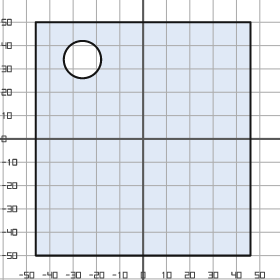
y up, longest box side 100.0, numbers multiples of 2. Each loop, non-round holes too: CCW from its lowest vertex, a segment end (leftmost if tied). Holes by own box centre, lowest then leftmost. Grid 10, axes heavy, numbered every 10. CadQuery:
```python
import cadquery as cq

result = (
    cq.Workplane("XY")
    .moveTo(-46.0, -50.0)
    .lineTo(46.0, -50.0)
    .lineTo(46.0, 50.0)
    .lineTo(-46.0, 50.0)
    .close()
    .moveTo(-26.0, 34.0)
    .circle(8.0)
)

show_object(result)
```